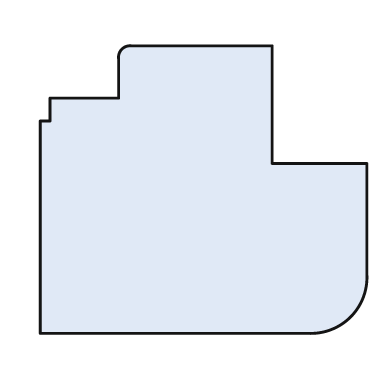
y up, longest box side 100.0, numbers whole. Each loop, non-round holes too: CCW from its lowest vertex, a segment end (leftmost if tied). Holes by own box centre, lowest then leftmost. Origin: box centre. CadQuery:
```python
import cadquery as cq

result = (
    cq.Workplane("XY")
    .moveTo(-50.0, -44.0)
    .lineTo(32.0, -44.0)
    .threePointArc((45.0, -39.0), (50.0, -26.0))
    .lineTo(50.0, 8.0)
    .lineTo(21.0, 8.0)
    .lineTo(21.0, 44.0)
    .lineTo(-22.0, 44.0)
    .threePointArc((-25.0, 43.0), (-26.0, 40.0))
    .lineTo(-26.0, 28.0)
    .lineTo(-47.0, 28.0)
    .lineTo(-47.0, 21.0)
    .lineTo(-50.0, 21.0)
    .close()
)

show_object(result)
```